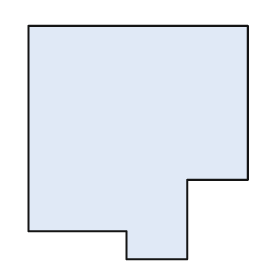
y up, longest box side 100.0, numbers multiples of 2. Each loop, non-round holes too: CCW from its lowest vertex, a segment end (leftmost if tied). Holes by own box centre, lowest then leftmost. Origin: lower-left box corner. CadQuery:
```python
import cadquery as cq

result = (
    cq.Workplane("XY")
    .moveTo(42.0, 0.0)
    .lineTo(68.0, 0.0)
    .lineTo(68.0, 34.0)
    .lineTo(94.0, 34.0)
    .lineTo(94.0, 100.0)
    .lineTo(0.0, 100.0)
    .lineTo(0.0, 12.0)
    .lineTo(42.0, 12.0)
    .close()
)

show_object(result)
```